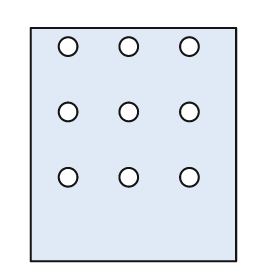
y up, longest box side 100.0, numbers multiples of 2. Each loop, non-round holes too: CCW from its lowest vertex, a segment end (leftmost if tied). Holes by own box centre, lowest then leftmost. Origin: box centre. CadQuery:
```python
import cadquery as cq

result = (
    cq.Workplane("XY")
    .moveTo(-44.0, -50.0)
    .lineTo(44.0, -50.0)
    .lineTo(44.0, 50.0)
    .lineTo(-44.0, 50.0)
    .close()
    .moveTo(-28.0, -14.0)
    .circle(4.0)
    .moveTo(-2.0, -14.0)
    .circle(4.0)
    .moveTo(24.0, -14.0)
    .circle(4.0)
    .moveTo(-28.0, 14.0)
    .circle(4.0)
    .moveTo(-2.0, 14.0)
    .circle(4.0)
    .moveTo(24.0, 14.0)
    .circle(4.0)
    .moveTo(-28.0, 42.0)
    .circle(4.0)
    .moveTo(-2.0, 42.0)
    .circle(4.0)
    .moveTo(24.0, 42.0)
    .circle(4.0)
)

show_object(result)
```